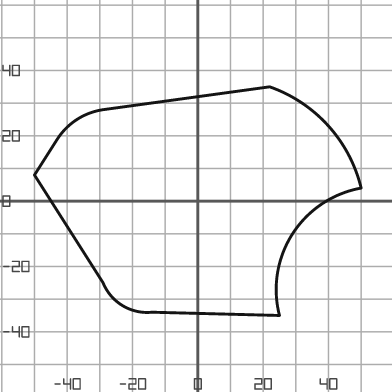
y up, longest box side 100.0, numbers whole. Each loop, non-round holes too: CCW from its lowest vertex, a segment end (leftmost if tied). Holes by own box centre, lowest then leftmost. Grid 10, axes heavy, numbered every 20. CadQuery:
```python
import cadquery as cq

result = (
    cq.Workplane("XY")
    .moveTo(25.0, -35.0)
    .threePointArc((29.0, -10.0), (50.0, 4.0))
    .threePointArc((40.0, 23.0), (22.0, 35.0))
    .lineTo(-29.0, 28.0)
    .threePointArc((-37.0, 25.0), (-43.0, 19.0))
    .lineTo(-50.0, 8.0)
    .lineTo(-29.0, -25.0)
    .threePointArc((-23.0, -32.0), (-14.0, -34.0))
    .close()
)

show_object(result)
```